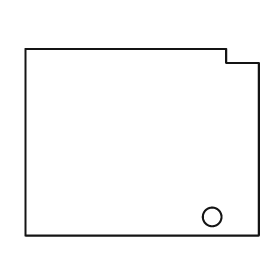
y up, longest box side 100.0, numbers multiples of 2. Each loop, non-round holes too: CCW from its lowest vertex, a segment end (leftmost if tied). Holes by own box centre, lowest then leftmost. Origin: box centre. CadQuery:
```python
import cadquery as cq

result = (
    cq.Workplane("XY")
    .moveTo(-50.0, -40.0)
    .lineTo(50.0, -40.0)
    .lineTo(50.0, 34.0)
    .lineTo(36.0, 34.0)
    .lineTo(36.0, 40.0)
    .lineTo(-50.0, 40.0)
    .close()
    .moveTo(30.0, -32.0)
    .circle(4.0)
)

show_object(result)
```